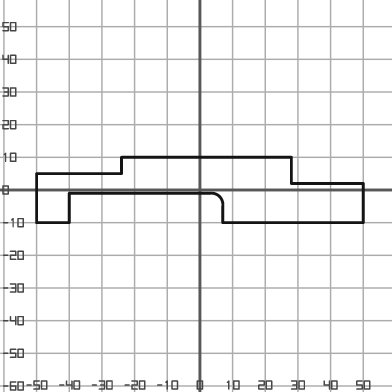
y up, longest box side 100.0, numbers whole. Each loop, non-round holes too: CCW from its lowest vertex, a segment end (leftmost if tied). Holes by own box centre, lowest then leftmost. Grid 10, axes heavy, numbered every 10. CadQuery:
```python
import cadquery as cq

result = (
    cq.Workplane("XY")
    .moveTo(-50.0, -10.0)
    .lineTo(-40.0, -10.0)
    .lineTo(-40.0, -1.0)
    .lineTo(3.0, -1.0)
    .threePointArc((6.0, -2.0), (7.0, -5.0))
    .lineTo(7.0, -10.0)
    .lineTo(50.0, -10.0)
    .lineTo(50.0, 2.0)
    .lineTo(28.0, 2.0)
    .lineTo(28.0, 10.0)
    .lineTo(-24.0, 10.0)
    .lineTo(-24.0, 5.0)
    .lineTo(-50.0, 5.0)
    .close()
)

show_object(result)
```